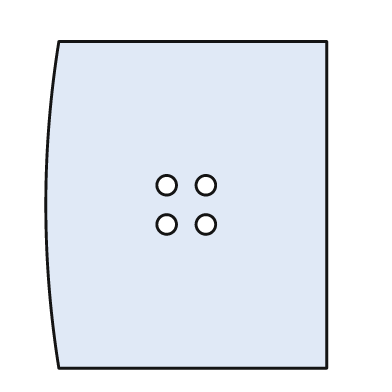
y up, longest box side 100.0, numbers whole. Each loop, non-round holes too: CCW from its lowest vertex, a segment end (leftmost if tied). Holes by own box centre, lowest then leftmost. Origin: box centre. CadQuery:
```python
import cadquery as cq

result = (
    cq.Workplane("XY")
    .moveTo(-39.0, -50.0)
    .lineTo(43.0, -50.0)
    .lineTo(43.0, 50.0)
    .lineTo(-39.0, 50.0)
    .threePointArc((-43.0, 0.0), (-39.0, -50.0))
    .close()
    .moveTo(-6.0, -6.0)
    .circle(3.0)
    .moveTo(6.0, -6.0)
    .circle(3.0)
    .moveTo(-6.0, 6.0)
    .circle(3.0)
    .moveTo(6.0, 6.0)
    .circle(3.0)
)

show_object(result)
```